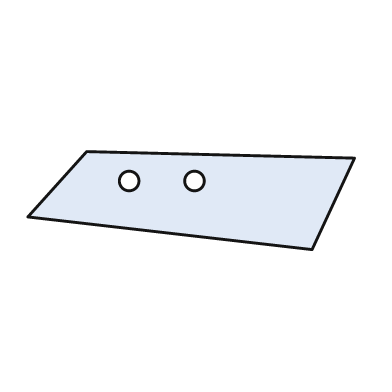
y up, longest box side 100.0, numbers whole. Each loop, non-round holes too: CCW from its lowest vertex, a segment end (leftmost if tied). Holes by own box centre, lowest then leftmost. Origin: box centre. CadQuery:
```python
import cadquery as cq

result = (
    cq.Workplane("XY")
    .moveTo(37.0, -15.0)
    .lineTo(50.0, 13.0)
    .lineTo(-32.0, 15.0)
    .lineTo(-50.0, -5.0)
    .close()
    .moveTo(-19.0, 6.0)
    .circle(3.0)
    .moveTo(1.0, 6.0)
    .circle(3.0)
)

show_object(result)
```